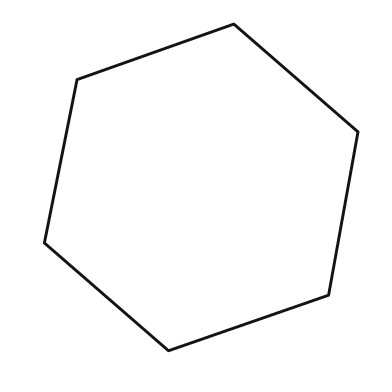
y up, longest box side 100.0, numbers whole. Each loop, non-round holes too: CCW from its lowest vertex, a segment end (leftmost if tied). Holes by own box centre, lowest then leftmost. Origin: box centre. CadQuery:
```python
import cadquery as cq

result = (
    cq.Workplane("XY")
    .moveTo(-10.0, -50.0)
    .lineTo(39.0, -33.0)
    .lineTo(48.0, 17.0)
    .lineTo(10.0, 50.0)
    .lineTo(-38.0, 33.0)
    .lineTo(-48.0, -17.0)
    .close()
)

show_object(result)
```